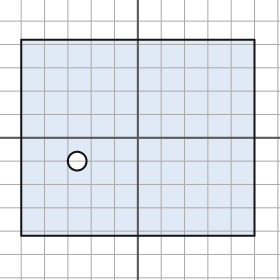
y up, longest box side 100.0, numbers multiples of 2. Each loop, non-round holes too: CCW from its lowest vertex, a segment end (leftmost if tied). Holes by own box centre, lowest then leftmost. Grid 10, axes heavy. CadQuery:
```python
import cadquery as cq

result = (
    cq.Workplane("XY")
    .moveTo(-50.0, -42.0)
    .lineTo(50.0, -42.0)
    .lineTo(50.0, 42.0)
    .lineTo(-50.0, 42.0)
    .close()
    .moveTo(-26.0, -10.0)
    .circle(4.0)
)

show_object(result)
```